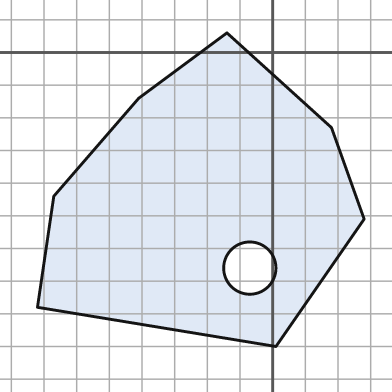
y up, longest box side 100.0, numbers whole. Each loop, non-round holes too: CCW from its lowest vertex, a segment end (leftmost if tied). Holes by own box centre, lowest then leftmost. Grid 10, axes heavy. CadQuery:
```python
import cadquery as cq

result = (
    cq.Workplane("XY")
    .moveTo(1.0, -90.0)
    .lineTo(28.0, -51.0)
    .lineTo(18.0, -23.0)
    .lineTo(-14.0, 6.0)
    .lineTo(-41.0, -14.0)
    .lineTo(-67.0, -44.0)
    .lineTo(-72.0, -78.0)
    .close()
    .moveTo(-7.0, -66.0)
    .circle(8.0)
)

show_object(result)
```